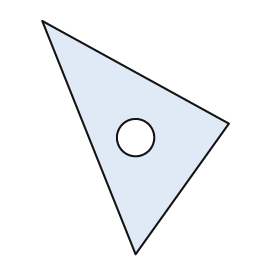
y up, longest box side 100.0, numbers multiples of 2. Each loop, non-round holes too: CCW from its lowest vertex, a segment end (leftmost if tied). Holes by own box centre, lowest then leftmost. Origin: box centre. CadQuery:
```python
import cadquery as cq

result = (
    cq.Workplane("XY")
    .moveTo(0.0, -50.0)
    .lineTo(40.0, 6.0)
    .lineTo(-40.0, 50.0)
    .close()
    .moveTo(0.0, 0.0)
    .circle(8.0)
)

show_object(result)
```